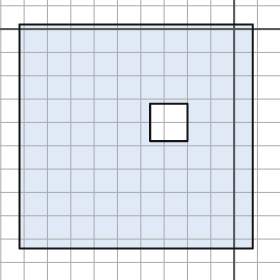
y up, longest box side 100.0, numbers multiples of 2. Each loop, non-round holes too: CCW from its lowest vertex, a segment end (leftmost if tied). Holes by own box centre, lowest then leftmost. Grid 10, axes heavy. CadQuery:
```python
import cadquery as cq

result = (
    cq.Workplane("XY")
    .moveTo(-92.0, -94.0)
    .lineTo(8.0, -94.0)
    .lineTo(8.0, 2.0)
    .lineTo(-92.0, 2.0)
    .close()
    .moveTo(-36.0, -48.0)
    .lineTo(-20.0, -48.0)
    .lineTo(-20.0, -32.0)
    .lineTo(-36.0, -32.0)
    .close()
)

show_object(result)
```